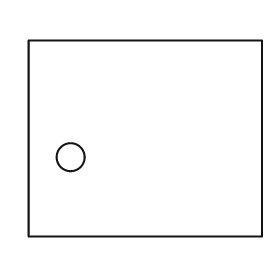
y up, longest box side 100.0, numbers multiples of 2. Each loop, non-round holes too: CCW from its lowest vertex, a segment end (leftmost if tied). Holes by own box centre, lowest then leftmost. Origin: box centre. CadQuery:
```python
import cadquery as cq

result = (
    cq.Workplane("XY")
    .moveTo(-50.0, -42.0)
    .lineTo(50.0, -42.0)
    .lineTo(50.0, 42.0)
    .lineTo(-50.0, 42.0)
    .close()
    .moveTo(-32.0, -8.0)
    .circle(6.0)
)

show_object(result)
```